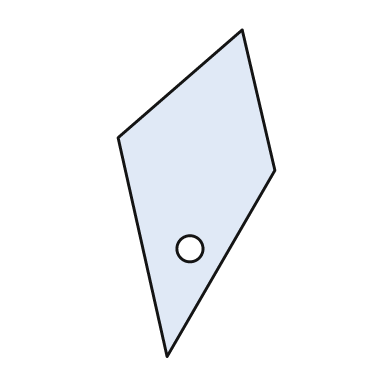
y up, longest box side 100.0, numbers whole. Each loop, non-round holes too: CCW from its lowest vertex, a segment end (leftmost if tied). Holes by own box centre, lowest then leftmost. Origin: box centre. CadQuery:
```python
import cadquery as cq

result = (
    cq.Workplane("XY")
    .moveTo(-9.0, -50.0)
    .lineTo(24.0, 7.0)
    .lineTo(14.0, 50.0)
    .lineTo(-24.0, 17.0)
    .close()
    .moveTo(-2.0, -17.0)
    .circle(4.0)
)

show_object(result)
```